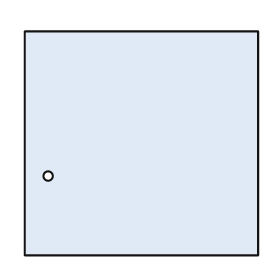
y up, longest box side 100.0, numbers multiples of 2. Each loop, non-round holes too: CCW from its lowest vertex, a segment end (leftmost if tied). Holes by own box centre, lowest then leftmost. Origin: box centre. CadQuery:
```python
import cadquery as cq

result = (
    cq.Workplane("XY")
    .moveTo(-50.0, -48.0)
    .lineTo(50.0, -48.0)
    .lineTo(50.0, 48.0)
    .lineTo(-50.0, 48.0)
    .close()
    .moveTo(-40.0, -14.0)
    .circle(2.0)
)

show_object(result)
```